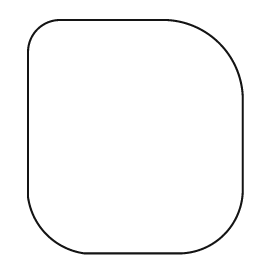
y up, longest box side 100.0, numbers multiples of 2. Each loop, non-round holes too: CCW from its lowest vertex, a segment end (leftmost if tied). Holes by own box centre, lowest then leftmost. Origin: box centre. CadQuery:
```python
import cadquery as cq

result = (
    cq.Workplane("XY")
    .moveTo(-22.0, -50.0)
    .lineTo(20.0, -50.0)
    .threePointArc((38.0, -42.0), (46.0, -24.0))
    .lineTo(46.0, 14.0)
    .threePointArc((36.0, 40.0), (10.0, 50.0))
    .lineTo(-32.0, 50.0)
    .threePointArc((-42.0, 46.0), (-46.0, 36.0))
    .lineTo(-46.0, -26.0)
    .threePointArc((-38.0, -42.0), (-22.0, -50.0))
    .close()
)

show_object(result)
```